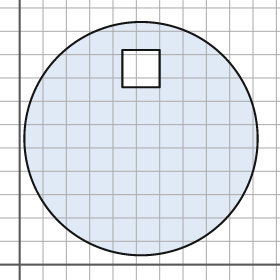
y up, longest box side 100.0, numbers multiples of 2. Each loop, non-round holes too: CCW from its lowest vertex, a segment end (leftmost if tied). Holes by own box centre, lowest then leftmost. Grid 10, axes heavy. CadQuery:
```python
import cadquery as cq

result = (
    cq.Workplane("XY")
    .moveTo(52.0, 54.0)
    .circle(50.0)
    .moveTo(44.0, 76.0)
    .lineTo(60.0, 76.0)
    .lineTo(60.0, 92.0)
    .lineTo(44.0, 92.0)
    .close()
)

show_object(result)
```